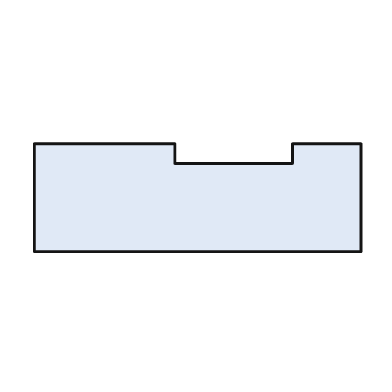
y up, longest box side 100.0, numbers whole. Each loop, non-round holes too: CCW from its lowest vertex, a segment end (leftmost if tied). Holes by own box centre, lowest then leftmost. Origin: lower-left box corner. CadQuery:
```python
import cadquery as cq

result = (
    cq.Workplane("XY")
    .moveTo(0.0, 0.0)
    .lineTo(100.0, 0.0)
    .lineTo(100.0, 33.0)
    .lineTo(79.0, 33.0)
    .lineTo(79.0, 27.0)
    .lineTo(43.0, 27.0)
    .lineTo(43.0, 33.0)
    .lineTo(0.0, 33.0)
    .close()
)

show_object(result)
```